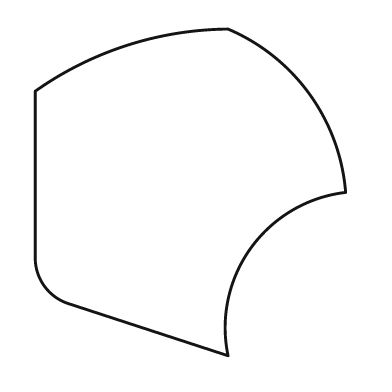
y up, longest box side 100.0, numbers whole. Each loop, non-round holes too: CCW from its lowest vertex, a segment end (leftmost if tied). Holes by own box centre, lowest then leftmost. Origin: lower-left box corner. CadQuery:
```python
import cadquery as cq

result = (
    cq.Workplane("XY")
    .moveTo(59.0, 0.0)
    .threePointArc((66.0, 33.0), (95.0, 50.0))
    .threePointArc((84.0, 80.0), (59.0, 100.0))
    .threePointArc((28.0, 95.0), (0.0, 81.0))
    .lineTo(0.0, 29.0)
    .threePointArc((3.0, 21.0), (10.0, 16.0))
    .close()
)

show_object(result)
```